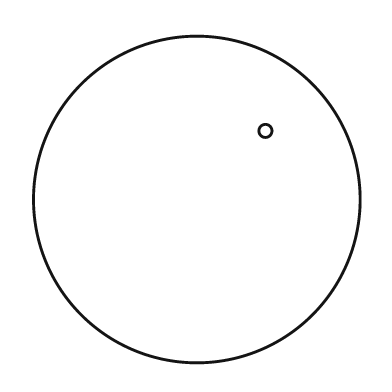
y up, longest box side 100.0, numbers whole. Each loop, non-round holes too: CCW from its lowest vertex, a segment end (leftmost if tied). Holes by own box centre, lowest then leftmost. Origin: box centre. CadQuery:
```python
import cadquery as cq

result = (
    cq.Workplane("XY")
    .moveTo(0.0, 0.0)
    .circle(50.0)
    .moveTo(21.0, 21.0)
    .circle(2.0)
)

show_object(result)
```